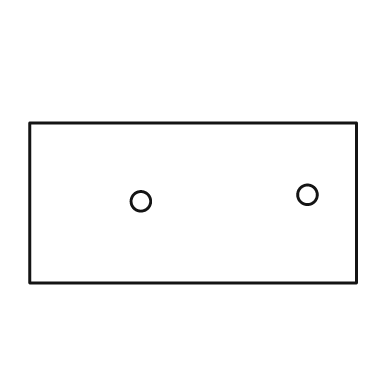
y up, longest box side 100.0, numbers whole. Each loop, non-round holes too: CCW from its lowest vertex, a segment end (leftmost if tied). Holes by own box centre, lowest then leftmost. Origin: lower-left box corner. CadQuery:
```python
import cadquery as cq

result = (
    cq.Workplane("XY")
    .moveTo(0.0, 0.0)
    .lineTo(100.0, 0.0)
    .lineTo(100.0, 49.0)
    .lineTo(0.0, 49.0)
    .close()
    .moveTo(34.0, 25.0)
    .circle(3.0)
    .moveTo(85.0, 27.0)
    .circle(3.0)
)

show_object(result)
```